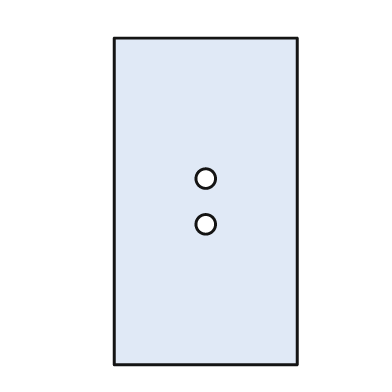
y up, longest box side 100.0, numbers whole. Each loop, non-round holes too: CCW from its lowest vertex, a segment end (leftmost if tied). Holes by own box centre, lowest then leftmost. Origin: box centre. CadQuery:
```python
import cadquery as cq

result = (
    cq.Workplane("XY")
    .moveTo(-28.0, -50.0)
    .lineTo(28.0, -50.0)
    .lineTo(28.0, 50.0)
    .lineTo(-28.0, 50.0)
    .close()
    .moveTo(0.0, -7.0)
    .circle(3.0)
    .moveTo(0.0, 7.0)
    .circle(3.0)
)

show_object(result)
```